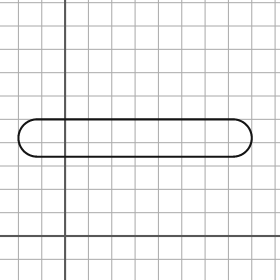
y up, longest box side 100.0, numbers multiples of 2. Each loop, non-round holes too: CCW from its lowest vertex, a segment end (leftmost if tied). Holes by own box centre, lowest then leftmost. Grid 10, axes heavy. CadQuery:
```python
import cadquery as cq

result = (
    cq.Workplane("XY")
    .moveTo(-12.0, 34.0)
    .lineTo(72.0, 34.0)
    .threePointArc((80.0, 42.0), (72.0, 50.0))
    .lineTo(-12.0, 50.0)
    .threePointArc((-20.0, 42.0), (-12.0, 34.0))
    .close()
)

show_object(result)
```